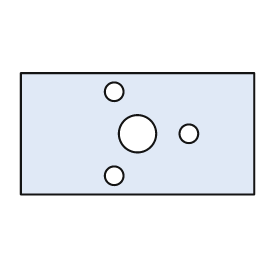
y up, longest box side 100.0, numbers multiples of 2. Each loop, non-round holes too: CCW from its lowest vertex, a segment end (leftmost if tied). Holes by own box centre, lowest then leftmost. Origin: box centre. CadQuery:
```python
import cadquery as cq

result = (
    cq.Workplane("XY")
    .moveTo(-50.0, -26.0)
    .lineTo(50.0, -26.0)
    .lineTo(50.0, 26.0)
    .lineTo(-50.0, 26.0)
    .close()
    .moveTo(-10.0, -18.0)
    .circle(4.0)
    .moveTo(0.0, 0.0)
    .circle(8.0)
    .moveTo(22.0, 0.0)
    .circle(4.0)
    .moveTo(-10.0, 18.0)
    .circle(4.0)
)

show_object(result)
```